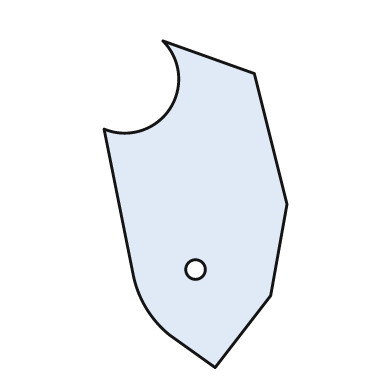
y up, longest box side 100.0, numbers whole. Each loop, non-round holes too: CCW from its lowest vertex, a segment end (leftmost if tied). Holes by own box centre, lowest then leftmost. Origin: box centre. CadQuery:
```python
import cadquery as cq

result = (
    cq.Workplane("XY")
    .moveTo(6.0, -50.0)
    .lineTo(23.0, -28.0)
    .lineTo(28.0, 0.0)
    .lineTo(18.0, 40.0)
    .lineTo(-10.0, 50.0)
    .threePointArc((-8.0, 29.0), (-28.0, 23.0))
    .lineTo(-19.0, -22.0)
    .threePointArc((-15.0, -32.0), (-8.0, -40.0))
    .close()
    .moveTo(0.0, -20.0)
    .circle(3.0)
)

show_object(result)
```